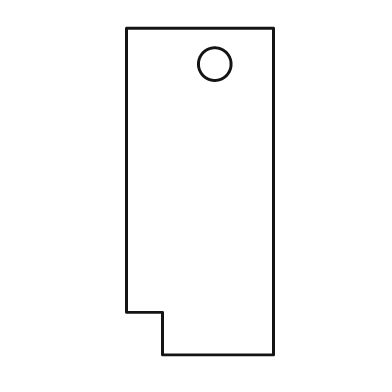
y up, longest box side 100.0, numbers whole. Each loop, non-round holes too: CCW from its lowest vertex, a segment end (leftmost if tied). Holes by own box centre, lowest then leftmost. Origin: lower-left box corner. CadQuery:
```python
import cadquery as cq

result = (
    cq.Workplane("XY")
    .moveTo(11.0, 0.0)
    .lineTo(45.0, 0.0)
    .lineTo(45.0, 100.0)
    .lineTo(0.0, 100.0)
    .lineTo(0.0, 13.0)
    .lineTo(11.0, 13.0)
    .close()
    .moveTo(27.0, 89.0)
    .circle(5.0)
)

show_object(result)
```